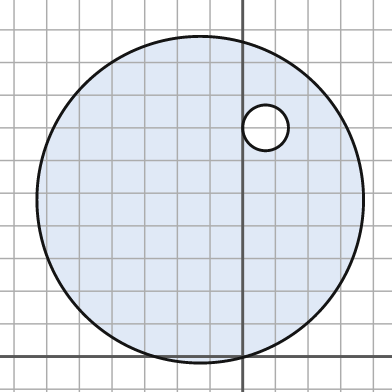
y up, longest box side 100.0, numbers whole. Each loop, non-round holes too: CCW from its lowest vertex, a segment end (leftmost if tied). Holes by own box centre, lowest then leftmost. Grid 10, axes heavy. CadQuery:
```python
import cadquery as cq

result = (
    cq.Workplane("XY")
    .moveTo(-13.0, 48.0)
    .circle(50.0)
    .moveTo(7.0, 70.0)
    .circle(7.0)
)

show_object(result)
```